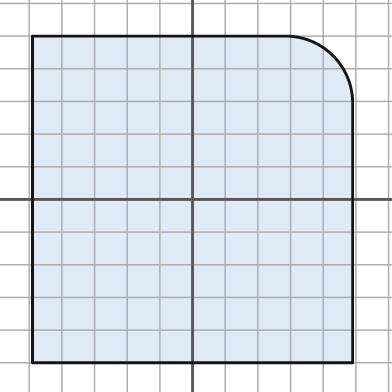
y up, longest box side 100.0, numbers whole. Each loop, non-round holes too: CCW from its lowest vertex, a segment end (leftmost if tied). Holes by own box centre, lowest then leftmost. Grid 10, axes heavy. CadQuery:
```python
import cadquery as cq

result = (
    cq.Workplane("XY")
    .moveTo(-49.0, -50.0)
    .lineTo(49.0, -50.0)
    .lineTo(49.0, 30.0)
    .threePointArc((43.0, 44.0), (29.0, 50.0))
    .lineTo(-49.0, 50.0)
    .close()
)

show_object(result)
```